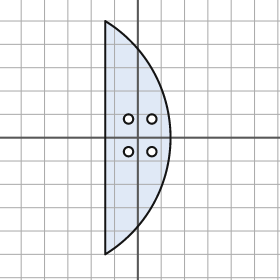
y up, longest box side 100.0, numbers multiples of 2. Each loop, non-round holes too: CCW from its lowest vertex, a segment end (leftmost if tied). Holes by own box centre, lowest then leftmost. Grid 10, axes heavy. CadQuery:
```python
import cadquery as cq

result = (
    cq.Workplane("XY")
    .moveTo(-14.0, -50.0)
    .threePointArc((14.0, 0.0), (-14.0, 50.0))
    .close()
    .moveTo(-4.0, -6.0)
    .circle(2.0)
    .moveTo(6.0, -6.0)
    .circle(2.0)
    .moveTo(-4.0, 8.0)
    .circle(2.0)
    .moveTo(6.0, 8.0)
    .circle(2.0)
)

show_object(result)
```